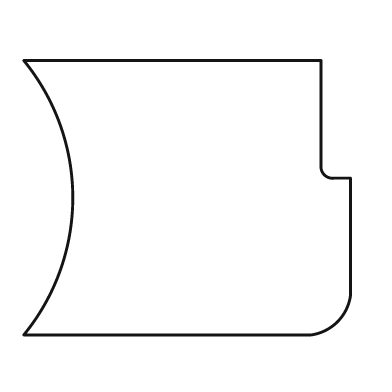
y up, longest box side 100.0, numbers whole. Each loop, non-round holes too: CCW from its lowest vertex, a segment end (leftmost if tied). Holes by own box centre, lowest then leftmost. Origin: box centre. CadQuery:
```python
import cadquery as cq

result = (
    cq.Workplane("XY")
    .moveTo(-50.0, -42.0)
    .lineTo(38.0, -42.0)
    .threePointArc((46.0, -38.0), (50.0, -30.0))
    .lineTo(50.0, 6.0)
    .lineTo(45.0, 6.0)
    .threePointArc((42.0, 7.0), (41.0, 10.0))
    .lineTo(41.0, 42.0)
    .lineTo(-50.0, 42.0)
    .threePointArc((-35.0, 0.0), (-50.0, -42.0))
    .close()
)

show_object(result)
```